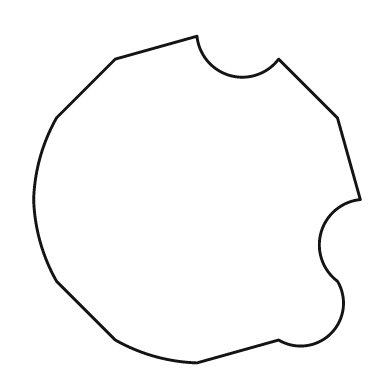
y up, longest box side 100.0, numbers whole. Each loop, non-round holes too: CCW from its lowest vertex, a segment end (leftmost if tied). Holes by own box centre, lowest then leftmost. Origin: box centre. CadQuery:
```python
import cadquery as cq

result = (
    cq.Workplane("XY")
    .moveTo(0.0, -50.0)
    .lineTo(25.0, -43.0)
    .threePointArc((41.0, -41.0), (43.0, -25.0))
    .threePointArc((38.0, -10.0), (50.0, 0.0))
    .lineTo(43.0, 25.0)
    .lineTo(25.0, 43.0)
    .threePointArc((10.0, 38.0), (0.0, 50.0))
    .lineTo(-25.0, 43.0)
    .lineTo(-43.0, 25.0)
    .threePointArc((-48.0, 13.0), (-50.0, 0.0))
    .threePointArc((-48.0, -13.0), (-43.0, -25.0))
    .lineTo(-25.0, -43.0)
    .threePointArc((-13.0, -48.0), (0.0, -50.0))
    .close()
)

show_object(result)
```